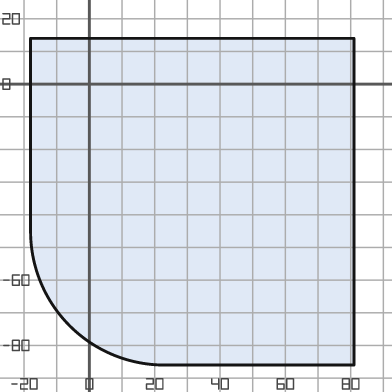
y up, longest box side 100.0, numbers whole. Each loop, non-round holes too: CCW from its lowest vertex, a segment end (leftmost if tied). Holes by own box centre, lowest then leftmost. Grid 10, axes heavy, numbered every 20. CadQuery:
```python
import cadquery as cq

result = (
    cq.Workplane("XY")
    .moveTo(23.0, -86.0)
    .lineTo(81.0, -86.0)
    .lineTo(81.0, 14.0)
    .lineTo(-18.0, 14.0)
    .lineTo(-18.0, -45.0)
    .threePointArc((-6.0, -74.0), (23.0, -86.0))
    .close()
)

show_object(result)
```